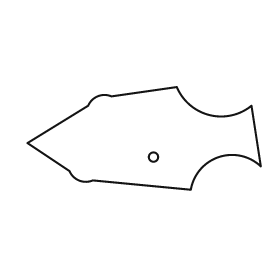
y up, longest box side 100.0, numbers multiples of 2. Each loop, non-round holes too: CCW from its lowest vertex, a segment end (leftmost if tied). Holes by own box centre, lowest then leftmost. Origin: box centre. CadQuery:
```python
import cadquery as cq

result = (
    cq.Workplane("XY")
    .moveTo(20.0, -22.0)
    .threePointArc((32.0, -8.0), (50.0, -12.0))
    .lineTo(46.0, 14.0)
    .threePointArc((28.0, 10.0), (14.0, 22.0))
    .lineTo(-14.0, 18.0)
    .threePointArc((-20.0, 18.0), (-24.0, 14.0))
    .lineTo(-50.0, -2.0)
    .lineTo(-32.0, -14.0)
    .threePointArc((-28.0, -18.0), (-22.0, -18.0))
    .close()
    .moveTo(4.0, -8.0)
    .circle(2.0)
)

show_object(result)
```